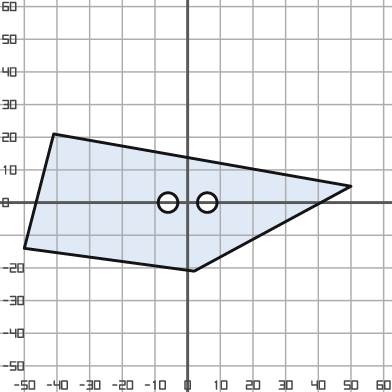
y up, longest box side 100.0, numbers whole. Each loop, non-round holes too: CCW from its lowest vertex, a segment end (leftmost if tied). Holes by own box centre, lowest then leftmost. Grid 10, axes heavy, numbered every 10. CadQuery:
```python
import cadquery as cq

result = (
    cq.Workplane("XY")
    .moveTo(2.0, -21.0)
    .lineTo(50.0, 5.0)
    .lineTo(-41.0, 21.0)
    .lineTo(-50.0, -14.0)
    .close()
    .moveTo(-6.0, 0.0)
    .circle(3.0)
    .moveTo(6.0, 0.0)
    .circle(3.0)
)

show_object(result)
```